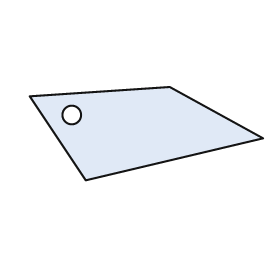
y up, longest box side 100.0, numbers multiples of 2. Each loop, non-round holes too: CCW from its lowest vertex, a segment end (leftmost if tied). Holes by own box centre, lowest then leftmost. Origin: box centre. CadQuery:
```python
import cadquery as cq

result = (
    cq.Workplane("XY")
    .moveTo(-26.0, -20.0)
    .lineTo(50.0, -2.0)
    .lineTo(10.0, 20.0)
    .lineTo(-50.0, 16.0)
    .close()
    .moveTo(-32.0, 8.0)
    .circle(4.0)
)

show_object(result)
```